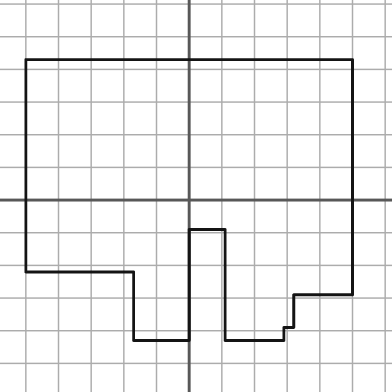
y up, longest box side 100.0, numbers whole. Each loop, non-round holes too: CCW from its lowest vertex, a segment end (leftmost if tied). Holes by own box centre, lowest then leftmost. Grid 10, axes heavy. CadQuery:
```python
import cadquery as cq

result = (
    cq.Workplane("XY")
    .moveTo(-17.0, -43.0)
    .lineTo(0.0, -43.0)
    .lineTo(0.0, -9.0)
    .lineTo(11.0, -9.0)
    .lineTo(11.0, -43.0)
    .lineTo(29.0, -43.0)
    .lineTo(29.0, -39.0)
    .lineTo(32.0, -39.0)
    .lineTo(32.0, -29.0)
    .lineTo(50.0, -29.0)
    .lineTo(50.0, 43.0)
    .lineTo(-50.0, 43.0)
    .lineTo(-50.0, -22.0)
    .lineTo(-17.0, -22.0)
    .close()
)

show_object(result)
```